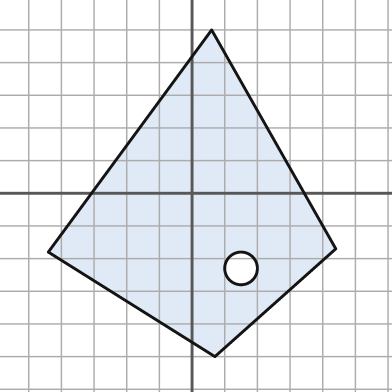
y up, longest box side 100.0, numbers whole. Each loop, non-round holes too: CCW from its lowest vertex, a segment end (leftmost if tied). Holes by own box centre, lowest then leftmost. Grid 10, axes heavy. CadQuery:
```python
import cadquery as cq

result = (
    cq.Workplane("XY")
    .moveTo(7.0, -50.0)
    .lineTo(44.0, -17.0)
    .lineTo(6.0, 50.0)
    .lineTo(-44.0, -18.0)
    .close()
    .moveTo(15.0, -23.0)
    .circle(5.0)
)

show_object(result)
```